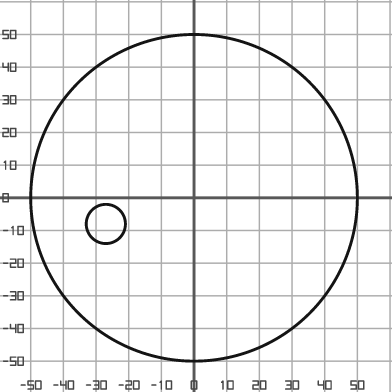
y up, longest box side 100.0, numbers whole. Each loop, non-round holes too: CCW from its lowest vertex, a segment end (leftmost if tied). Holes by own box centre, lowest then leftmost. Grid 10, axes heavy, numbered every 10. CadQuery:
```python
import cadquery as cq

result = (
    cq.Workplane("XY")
    .moveTo(0.0, 0.0)
    .circle(50.0)
    .moveTo(-27.0, -8.0)
    .circle(6.0)
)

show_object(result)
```